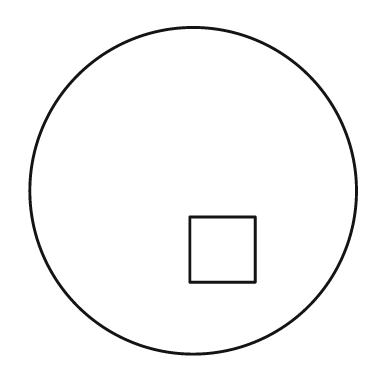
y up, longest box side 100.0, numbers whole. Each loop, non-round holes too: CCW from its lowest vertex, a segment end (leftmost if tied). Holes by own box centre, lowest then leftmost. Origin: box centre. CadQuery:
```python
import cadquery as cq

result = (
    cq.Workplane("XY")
    .moveTo(0.0, 0.0)
    .circle(50.0)
    .moveTo(-1.0, -28.0)
    .lineTo(19.0, -28.0)
    .lineTo(19.0, -8.0)
    .lineTo(-1.0, -8.0)
    .close()
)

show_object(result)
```